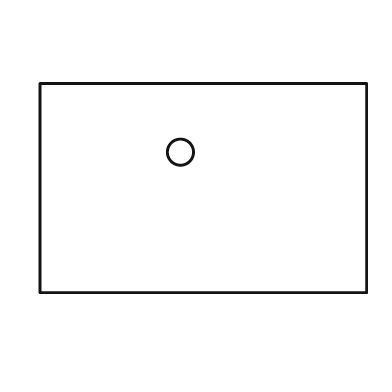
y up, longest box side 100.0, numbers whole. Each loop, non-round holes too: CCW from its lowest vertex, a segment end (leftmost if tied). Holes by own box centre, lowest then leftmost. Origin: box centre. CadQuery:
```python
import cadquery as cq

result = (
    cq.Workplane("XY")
    .moveTo(-50.0, -32.0)
    .lineTo(50.0, -32.0)
    .lineTo(50.0, 32.0)
    .lineTo(-50.0, 32.0)
    .close()
    .moveTo(-7.0, 11.0)
    .circle(4.0)
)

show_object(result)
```